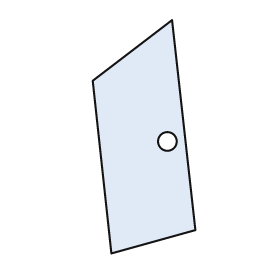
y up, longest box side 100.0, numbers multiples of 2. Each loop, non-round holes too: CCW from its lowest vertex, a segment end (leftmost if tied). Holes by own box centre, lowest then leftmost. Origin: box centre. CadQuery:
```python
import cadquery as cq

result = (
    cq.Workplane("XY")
    .moveTo(-14.0, -50.0)
    .lineTo(22.0, -40.0)
    .lineTo(12.0, 50.0)
    .lineTo(-22.0, 24.0)
    .close()
    .moveTo(10.0, -2.0)
    .circle(4.0)
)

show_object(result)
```